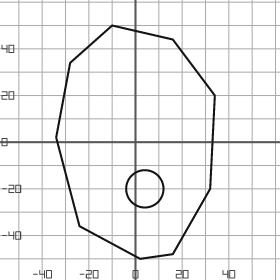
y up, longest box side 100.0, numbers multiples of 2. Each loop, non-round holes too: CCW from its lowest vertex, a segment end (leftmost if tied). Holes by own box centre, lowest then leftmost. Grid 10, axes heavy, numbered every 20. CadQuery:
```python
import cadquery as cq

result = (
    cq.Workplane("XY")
    .moveTo(2.0, -50.0)
    .lineTo(16.0, -48.0)
    .lineTo(32.0, -20.0)
    .lineTo(34.0, 20.0)
    .lineTo(16.0, 44.0)
    .lineTo(-10.0, 50.0)
    .lineTo(-28.0, 34.0)
    .lineTo(-34.0, 2.0)
    .lineTo(-24.0, -36.0)
    .close()
    .moveTo(4.0, -20.0)
    .circle(8.0)
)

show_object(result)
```